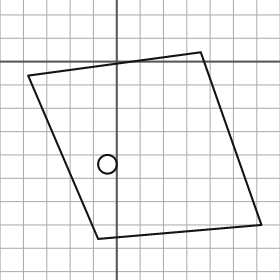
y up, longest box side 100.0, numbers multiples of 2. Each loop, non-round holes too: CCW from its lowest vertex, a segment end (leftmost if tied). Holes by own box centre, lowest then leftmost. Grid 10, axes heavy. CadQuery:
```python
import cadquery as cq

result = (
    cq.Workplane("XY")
    .moveTo(-8.0, -76.0)
    .lineTo(62.0, -70.0)
    .lineTo(36.0, 4.0)
    .lineTo(-38.0, -6.0)
    .close()
    .moveTo(-4.0, -44.0)
    .circle(4.0)
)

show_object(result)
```